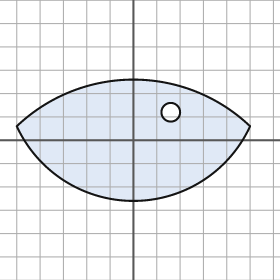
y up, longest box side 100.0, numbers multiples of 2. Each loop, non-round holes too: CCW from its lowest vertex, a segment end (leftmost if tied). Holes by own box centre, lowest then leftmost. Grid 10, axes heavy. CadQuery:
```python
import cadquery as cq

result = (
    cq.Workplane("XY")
    .moveTo(-50.0, 6.0)
    .threePointArc((0.0, -26.0), (50.0, 6.0))
    .threePointArc((0.0, 26.0), (-50.0, 6.0))
    .close()
    .moveTo(16.0, 12.0)
    .circle(4.0)
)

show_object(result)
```